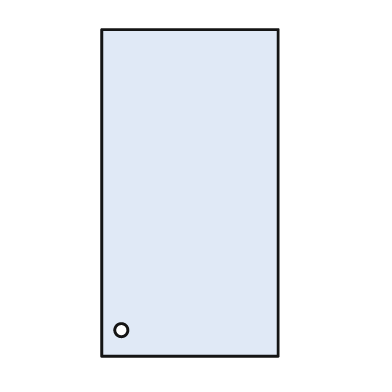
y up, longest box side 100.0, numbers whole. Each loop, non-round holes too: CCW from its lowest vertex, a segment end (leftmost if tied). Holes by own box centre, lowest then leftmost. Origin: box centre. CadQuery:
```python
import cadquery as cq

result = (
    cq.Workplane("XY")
    .moveTo(-27.0, -50.0)
    .lineTo(27.0, -50.0)
    .lineTo(27.0, 50.0)
    .lineTo(-27.0, 50.0)
    .close()
    .moveTo(-21.0, -42.0)
    .circle(2.0)
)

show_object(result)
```